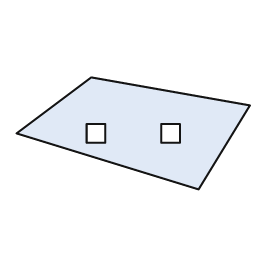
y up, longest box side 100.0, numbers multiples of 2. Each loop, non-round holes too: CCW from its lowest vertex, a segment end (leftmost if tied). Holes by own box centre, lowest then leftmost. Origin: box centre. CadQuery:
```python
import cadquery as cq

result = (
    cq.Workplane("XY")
    .moveTo(28.0, -24.0)
    .lineTo(50.0, 12.0)
    .lineTo(-18.0, 24.0)
    .lineTo(-50.0, 0.0)
    .close()
    .moveTo(-20.0, -4.0)
    .lineTo(-12.0, -4.0)
    .lineTo(-12.0, 4.0)
    .lineTo(-20.0, 4.0)
    .close()
    .moveTo(12.0, -4.0)
    .lineTo(20.0, -4.0)
    .lineTo(20.0, 4.0)
    .lineTo(12.0, 4.0)
    .close()
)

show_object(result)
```